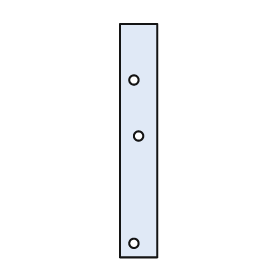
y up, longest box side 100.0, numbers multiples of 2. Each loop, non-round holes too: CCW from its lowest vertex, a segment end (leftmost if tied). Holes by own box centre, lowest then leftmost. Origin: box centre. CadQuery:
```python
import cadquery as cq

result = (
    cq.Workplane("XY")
    .moveTo(-8.0, -50.0)
    .lineTo(8.0, -50.0)
    .lineTo(8.0, 50.0)
    .lineTo(-8.0, 50.0)
    .close()
    .moveTo(-2.0, -44.0)
    .circle(2.0)
    .moveTo(0.0, 2.0)
    .circle(2.0)
    .moveTo(-2.0, 26.0)
    .circle(2.0)
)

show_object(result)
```